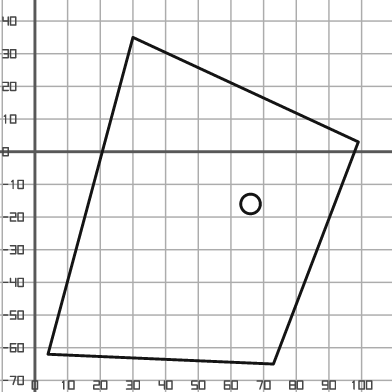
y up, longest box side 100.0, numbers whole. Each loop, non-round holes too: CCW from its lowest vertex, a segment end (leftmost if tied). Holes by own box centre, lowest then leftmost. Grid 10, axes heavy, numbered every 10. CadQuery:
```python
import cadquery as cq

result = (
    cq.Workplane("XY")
    .moveTo(73.0, -65.0)
    .lineTo(99.0, 3.0)
    .lineTo(30.0, 35.0)
    .lineTo(4.0, -62.0)
    .close()
    .moveTo(66.0, -16.0)
    .circle(3.0)
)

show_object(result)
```